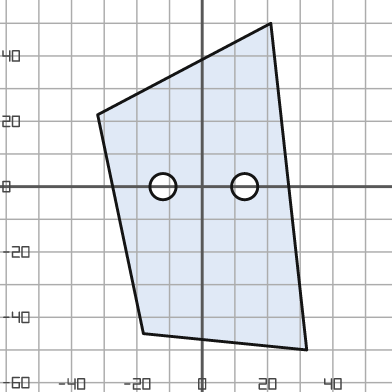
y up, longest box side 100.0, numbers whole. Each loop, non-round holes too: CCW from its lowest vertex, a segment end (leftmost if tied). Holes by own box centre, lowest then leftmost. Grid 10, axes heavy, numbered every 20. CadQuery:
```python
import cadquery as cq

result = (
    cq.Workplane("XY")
    .moveTo(32.0, -50.0)
    .lineTo(21.0, 50.0)
    .lineTo(-32.0, 22.0)
    .lineTo(-18.0, -45.0)
    .close()
    .moveTo(-12.0, 0.0)
    .circle(4.0)
    .moveTo(13.0, 0.0)
    .circle(4.0)
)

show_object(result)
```